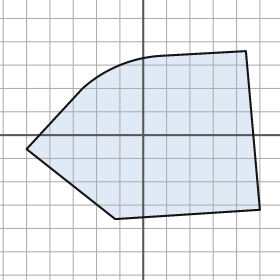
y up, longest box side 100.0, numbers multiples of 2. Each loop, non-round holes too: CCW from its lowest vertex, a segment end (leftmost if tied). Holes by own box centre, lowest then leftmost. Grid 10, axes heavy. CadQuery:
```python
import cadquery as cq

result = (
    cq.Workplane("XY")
    .moveTo(-12.0, -36.0)
    .lineTo(50.0, -32.0)
    .lineTo(44.0, 36.0)
    .lineTo(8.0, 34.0)
    .threePointArc((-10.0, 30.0), (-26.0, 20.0))
    .lineTo(-50.0, -6.0)
    .close()
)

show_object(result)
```